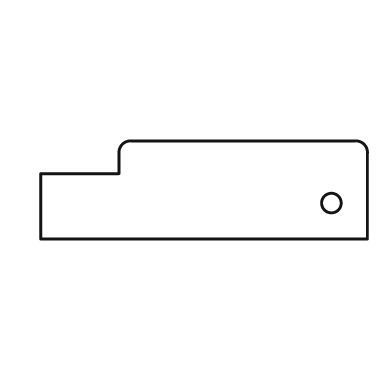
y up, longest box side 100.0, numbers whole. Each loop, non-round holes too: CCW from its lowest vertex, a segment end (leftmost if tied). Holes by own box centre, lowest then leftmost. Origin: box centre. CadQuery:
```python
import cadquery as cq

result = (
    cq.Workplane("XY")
    .moveTo(-50.0, -15.0)
    .lineTo(50.0, -15.0)
    .lineTo(50.0, 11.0)
    .threePointArc((49.0, 14.0), (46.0, 15.0))
    .lineTo(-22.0, 15.0)
    .threePointArc((-25.0, 14.0), (-26.0, 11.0))
    .lineTo(-26.0, 5.0)
    .lineTo(-50.0, 5.0)
    .close()
    .moveTo(39.0, -4.0)
    .circle(3.0)
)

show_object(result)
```